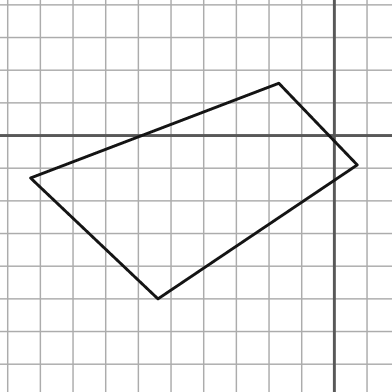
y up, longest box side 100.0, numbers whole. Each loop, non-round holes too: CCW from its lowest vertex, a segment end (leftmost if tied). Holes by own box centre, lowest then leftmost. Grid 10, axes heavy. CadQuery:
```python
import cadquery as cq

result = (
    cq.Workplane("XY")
    .moveTo(-54.0, -50.0)
    .lineTo(7.0, -9.0)
    .lineTo(-17.0, 16.0)
    .lineTo(-93.0, -13.0)
    .close()
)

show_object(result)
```